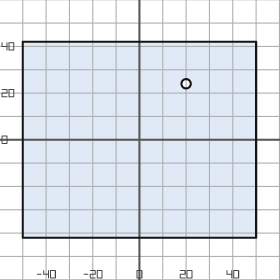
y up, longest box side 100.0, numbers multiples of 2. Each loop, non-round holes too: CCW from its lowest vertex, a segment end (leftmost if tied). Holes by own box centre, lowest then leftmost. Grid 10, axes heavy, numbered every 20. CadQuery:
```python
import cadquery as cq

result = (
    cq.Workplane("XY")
    .moveTo(-50.0, -42.0)
    .lineTo(50.0, -42.0)
    .lineTo(50.0, 42.0)
    .lineTo(-50.0, 42.0)
    .close()
    .moveTo(20.0, 24.0)
    .circle(2.0)
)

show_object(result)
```